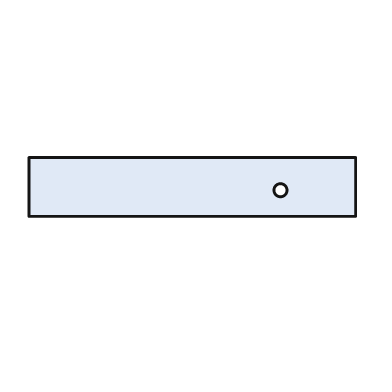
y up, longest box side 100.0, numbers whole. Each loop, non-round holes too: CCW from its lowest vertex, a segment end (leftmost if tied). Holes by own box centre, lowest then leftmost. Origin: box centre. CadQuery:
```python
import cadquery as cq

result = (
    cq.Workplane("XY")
    .moveTo(-50.0, -9.0)
    .lineTo(50.0, -9.0)
    .lineTo(50.0, 9.0)
    .lineTo(-50.0, 9.0)
    .close()
    .moveTo(27.0, -1.0)
    .circle(2.0)
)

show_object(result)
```